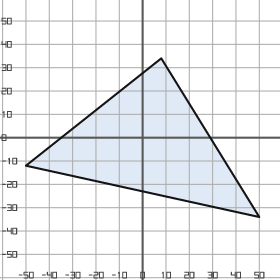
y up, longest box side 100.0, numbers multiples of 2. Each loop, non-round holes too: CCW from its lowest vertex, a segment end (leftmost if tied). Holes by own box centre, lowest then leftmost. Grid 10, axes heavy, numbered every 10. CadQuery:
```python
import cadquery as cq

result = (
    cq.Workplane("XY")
    .moveTo(50.0, -34.0)
    .lineTo(8.0, 34.0)
    .lineTo(-50.0, -12.0)
    .close()
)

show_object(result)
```